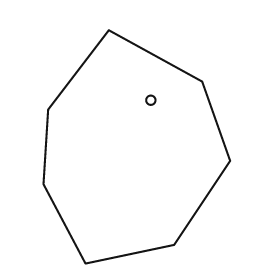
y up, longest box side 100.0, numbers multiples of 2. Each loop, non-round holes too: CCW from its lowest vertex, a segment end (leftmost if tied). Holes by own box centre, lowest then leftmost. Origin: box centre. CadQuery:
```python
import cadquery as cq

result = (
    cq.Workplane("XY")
    .moveTo(-22.0, -50.0)
    .lineTo(16.0, -42.0)
    .lineTo(40.0, -6.0)
    .lineTo(28.0, 28.0)
    .lineTo(-12.0, 50.0)
    .lineTo(-38.0, 16.0)
    .lineTo(-40.0, -16.0)
    .close()
    .moveTo(6.0, 20.0)
    .circle(2.0)
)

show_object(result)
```